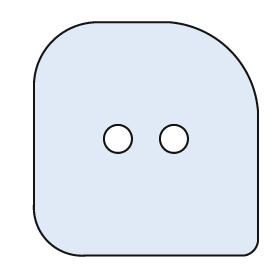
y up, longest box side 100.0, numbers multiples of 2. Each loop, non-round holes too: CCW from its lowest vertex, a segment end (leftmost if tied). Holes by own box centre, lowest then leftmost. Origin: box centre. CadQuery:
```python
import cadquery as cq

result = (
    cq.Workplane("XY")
    .moveTo(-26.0, -50.0)
    .lineTo(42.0, -50.0)
    .threePointArc((46.0, -48.0), (48.0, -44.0))
    .lineTo(48.0, 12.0)
    .threePointArc((36.0, 38.0), (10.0, 50.0))
    .lineTo(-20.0, 50.0)
    .threePointArc((-40.0, 42.0), (-48.0, 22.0))
    .lineTo(-48.0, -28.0)
    .threePointArc((-42.0, -44.0), (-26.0, -50.0))
    .close()
    .moveTo(-12.0, 0.0)
    .circle(6.0)
    .moveTo(12.0, 0.0)
    .circle(6.0)
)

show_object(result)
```